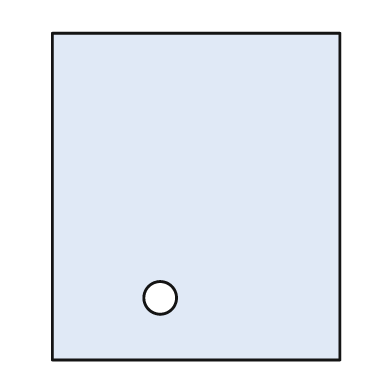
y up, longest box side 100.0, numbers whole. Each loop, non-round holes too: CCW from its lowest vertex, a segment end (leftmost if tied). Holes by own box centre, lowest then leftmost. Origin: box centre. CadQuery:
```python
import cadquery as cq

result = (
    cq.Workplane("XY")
    .moveTo(-44.0, -50.0)
    .lineTo(44.0, -50.0)
    .lineTo(44.0, 50.0)
    .lineTo(-44.0, 50.0)
    .close()
    .moveTo(-11.0, -31.0)
    .circle(5.0)
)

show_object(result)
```